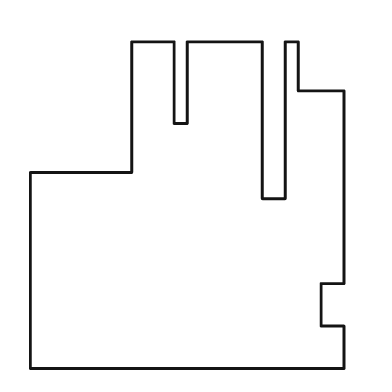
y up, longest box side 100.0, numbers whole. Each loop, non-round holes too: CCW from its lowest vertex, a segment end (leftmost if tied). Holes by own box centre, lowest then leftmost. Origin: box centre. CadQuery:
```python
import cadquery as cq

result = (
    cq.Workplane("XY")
    .moveTo(-48.0, -50.0)
    .lineTo(48.0, -50.0)
    .lineTo(48.0, -37.0)
    .lineTo(41.0, -37.0)
    .lineTo(41.0, -24.0)
    .lineTo(48.0, -24.0)
    .lineTo(48.0, 35.0)
    .lineTo(34.0, 35.0)
    .lineTo(34.0, 50.0)
    .lineTo(30.0, 50.0)
    .lineTo(30.0, 2.0)
    .lineTo(23.0, 2.0)
    .lineTo(23.0, 50.0)
    .lineTo(0.0, 50.0)
    .lineTo(0.0, 25.0)
    .lineTo(-4.0, 25.0)
    .lineTo(-4.0, 50.0)
    .lineTo(-17.0, 50.0)
    .lineTo(-17.0, 10.0)
    .lineTo(-48.0, 10.0)
    .close()
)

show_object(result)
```